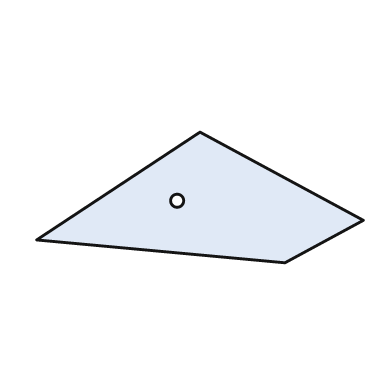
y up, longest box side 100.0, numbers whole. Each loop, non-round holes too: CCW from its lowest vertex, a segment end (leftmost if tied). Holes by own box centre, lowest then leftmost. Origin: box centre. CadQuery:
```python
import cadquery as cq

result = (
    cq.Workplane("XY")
    .moveTo(26.0, -20.0)
    .lineTo(50.0, -7.0)
    .lineTo(0.0, 20.0)
    .lineTo(-50.0, -13.0)
    .close()
    .moveTo(-7.0, -1.0)
    .circle(2.0)
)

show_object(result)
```